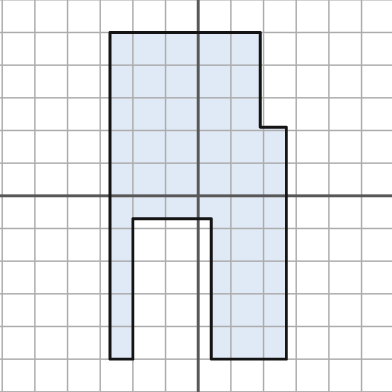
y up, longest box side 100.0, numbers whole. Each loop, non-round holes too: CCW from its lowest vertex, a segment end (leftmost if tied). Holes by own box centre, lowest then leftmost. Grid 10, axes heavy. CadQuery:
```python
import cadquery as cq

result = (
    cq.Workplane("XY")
    .moveTo(-27.0, -50.0)
    .lineTo(-20.0, -50.0)
    .lineTo(-20.0, -7.0)
    .lineTo(4.0, -7.0)
    .lineTo(4.0, -50.0)
    .lineTo(27.0, -50.0)
    .lineTo(27.0, 21.0)
    .lineTo(19.0, 21.0)
    .lineTo(19.0, 50.0)
    .lineTo(-27.0, 50.0)
    .close()
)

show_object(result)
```